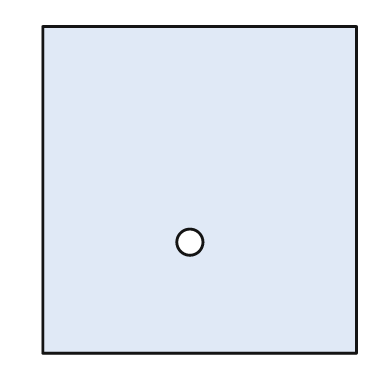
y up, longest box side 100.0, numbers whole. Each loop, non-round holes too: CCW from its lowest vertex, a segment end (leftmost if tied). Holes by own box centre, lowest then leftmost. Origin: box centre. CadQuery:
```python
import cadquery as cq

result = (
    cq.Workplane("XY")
    .moveTo(-48.0, -50.0)
    .lineTo(48.0, -50.0)
    .lineTo(48.0, 50.0)
    .lineTo(-48.0, 50.0)
    .close()
    .moveTo(-3.0, -16.0)
    .circle(4.0)
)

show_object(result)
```